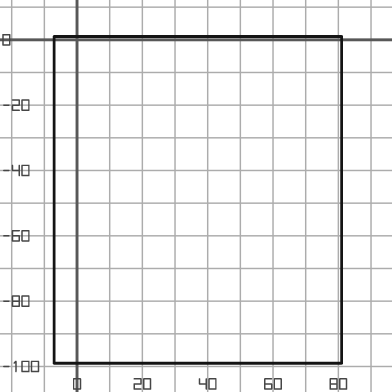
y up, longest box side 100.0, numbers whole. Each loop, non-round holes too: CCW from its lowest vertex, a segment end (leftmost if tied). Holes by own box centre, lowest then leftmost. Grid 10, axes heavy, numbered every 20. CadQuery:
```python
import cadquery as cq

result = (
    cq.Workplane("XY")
    .moveTo(-7.0, -99.0)
    .lineTo(81.0, -99.0)
    .lineTo(81.0, 1.0)
    .lineTo(-7.0, 1.0)
    .close()
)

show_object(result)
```